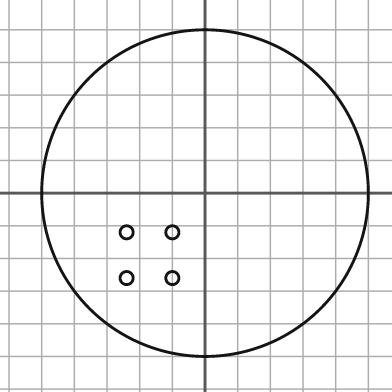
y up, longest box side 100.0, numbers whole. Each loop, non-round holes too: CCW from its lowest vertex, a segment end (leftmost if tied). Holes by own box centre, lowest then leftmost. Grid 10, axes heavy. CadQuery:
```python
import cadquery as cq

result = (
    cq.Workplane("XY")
    .moveTo(0.0, 0.0)
    .circle(50.0)
    .moveTo(-24.0, -26.0)
    .circle(2.0)
    .moveTo(-10.0, -26.0)
    .circle(2.0)
    .moveTo(-24.0, -12.0)
    .circle(2.0)
    .moveTo(-10.0, -12.0)
    .circle(2.0)
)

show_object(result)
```